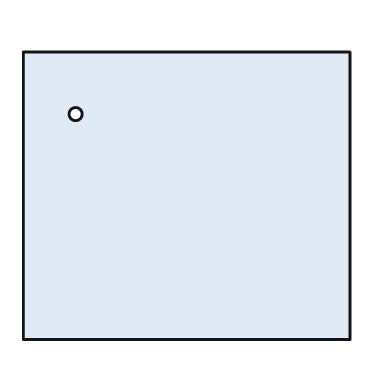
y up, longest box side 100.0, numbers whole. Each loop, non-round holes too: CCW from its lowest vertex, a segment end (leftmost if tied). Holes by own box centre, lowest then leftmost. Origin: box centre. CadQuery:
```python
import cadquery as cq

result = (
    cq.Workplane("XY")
    .moveTo(-50.0, -44.0)
    .lineTo(50.0, -44.0)
    .lineTo(50.0, 44.0)
    .lineTo(-50.0, 44.0)
    .close()
    .moveTo(-34.0, 25.0)
    .circle(2.0)
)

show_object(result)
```